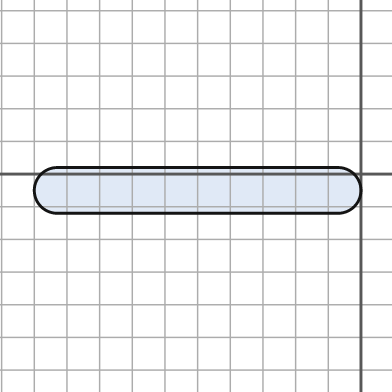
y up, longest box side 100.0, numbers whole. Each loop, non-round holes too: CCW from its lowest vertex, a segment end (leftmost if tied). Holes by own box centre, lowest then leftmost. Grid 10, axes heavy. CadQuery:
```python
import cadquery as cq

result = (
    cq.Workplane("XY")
    .moveTo(-93.0, -12.0)
    .lineTo(-7.0, -12.0)
    .threePointArc((0.0, -5.0), (-7.0, 2.0))
    .lineTo(-93.0, 2.0)
    .threePointArc((-100.0, -5.0), (-93.0, -12.0))
    .close()
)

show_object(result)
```